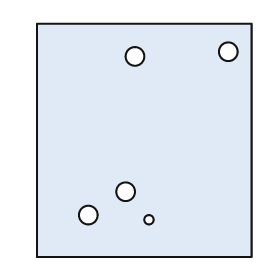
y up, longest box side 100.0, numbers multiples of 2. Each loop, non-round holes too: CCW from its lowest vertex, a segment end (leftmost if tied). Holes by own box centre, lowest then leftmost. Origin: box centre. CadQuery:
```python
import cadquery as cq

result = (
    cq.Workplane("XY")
    .moveTo(-46.0, -50.0)
    .lineTo(46.0, -50.0)
    .lineTo(46.0, 50.0)
    .lineTo(-46.0, 50.0)
    .close()
    .moveTo(2.0, -34.0)
    .circle(2.0)
    .moveTo(-24.0, -32.0)
    .circle(4.0)
    .moveTo(-8.0, -22.0)
    .circle(4.0)
    .moveTo(-4.0, 36.0)
    .circle(4.0)
    .moveTo(36.0, 38.0)
    .circle(4.0)
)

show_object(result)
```